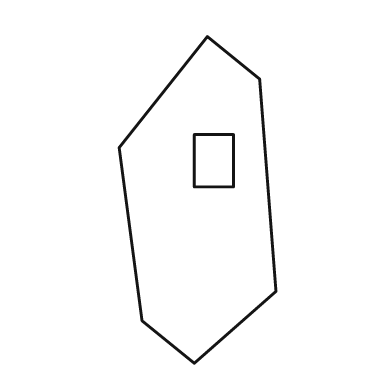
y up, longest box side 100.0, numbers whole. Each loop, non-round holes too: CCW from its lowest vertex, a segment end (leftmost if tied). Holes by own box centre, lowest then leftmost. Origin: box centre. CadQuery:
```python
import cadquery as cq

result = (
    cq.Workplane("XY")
    .moveTo(-1.0, -50.0)
    .lineTo(24.0, -28.0)
    .lineTo(19.0, 37.0)
    .lineTo(3.0, 50.0)
    .lineTo(-24.0, 16.0)
    .lineTo(-17.0, -37.0)
    .close()
    .moveTo(-1.0, 4.0)
    .lineTo(11.0, 4.0)
    .lineTo(11.0, 20.0)
    .lineTo(-1.0, 20.0)
    .close()
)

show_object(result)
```